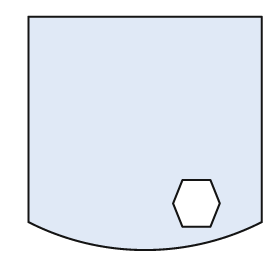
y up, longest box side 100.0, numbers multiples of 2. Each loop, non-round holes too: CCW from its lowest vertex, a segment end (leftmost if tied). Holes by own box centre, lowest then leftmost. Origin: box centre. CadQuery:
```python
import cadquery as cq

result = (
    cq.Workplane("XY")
    .moveTo(-50.0, -38.0)
    .threePointArc((0.0, -50.0), (50.0, -38.0))
    .lineTo(50.0, 50.0)
    .lineTo(-50.0, 50.0)
    .close()
    .moveTo(16.0, -40.0)
    .lineTo(28.0, -40.0)
    .lineTo(32.0, -30.0)
    .lineTo(28.0, -20.0)
    .lineTo(16.0, -20.0)
    .lineTo(12.0, -30.0)
    .close()
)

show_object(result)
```